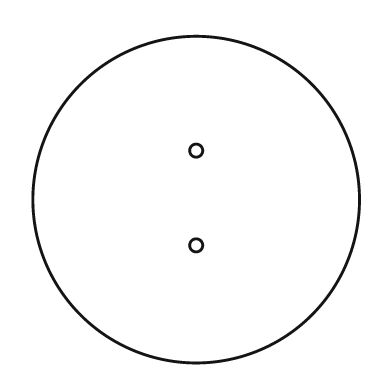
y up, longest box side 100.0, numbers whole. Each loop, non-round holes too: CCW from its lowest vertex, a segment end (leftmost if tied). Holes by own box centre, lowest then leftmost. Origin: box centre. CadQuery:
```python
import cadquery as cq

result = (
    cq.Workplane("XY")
    .moveTo(0.0, 0.0)
    .circle(50.0)
    .moveTo(0.0, -14.0)
    .circle(2.0)
    .moveTo(0.0, 15.0)
    .circle(2.0)
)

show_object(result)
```